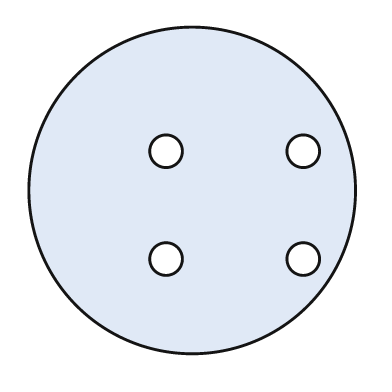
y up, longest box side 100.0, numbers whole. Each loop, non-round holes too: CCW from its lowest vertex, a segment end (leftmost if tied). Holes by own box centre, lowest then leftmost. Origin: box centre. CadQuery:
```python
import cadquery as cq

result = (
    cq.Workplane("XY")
    .moveTo(0.0, 0.0)
    .circle(50.0)
    .moveTo(-8.0, -21.0)
    .circle(5.0)
    .moveTo(34.0, -21.0)
    .circle(5.0)
    .moveTo(-8.0, 12.0)
    .circle(5.0)
    .moveTo(34.0, 12.0)
    .circle(5.0)
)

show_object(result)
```